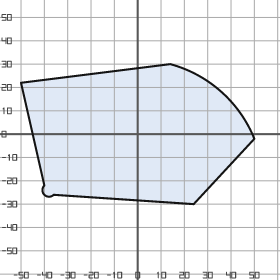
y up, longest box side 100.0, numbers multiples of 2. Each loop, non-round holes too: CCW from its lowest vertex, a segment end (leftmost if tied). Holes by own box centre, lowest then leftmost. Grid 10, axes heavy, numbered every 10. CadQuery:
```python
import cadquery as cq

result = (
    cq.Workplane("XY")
    .moveTo(24.0, -30.0)
    .lineTo(50.0, -2.0)
    .threePointArc((36.0, 18.0), (14.0, 30.0))
    .lineTo(-50.0, 22.0)
    .lineTo(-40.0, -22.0)
    .threePointArc((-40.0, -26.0), (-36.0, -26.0))
    .close()
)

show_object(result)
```